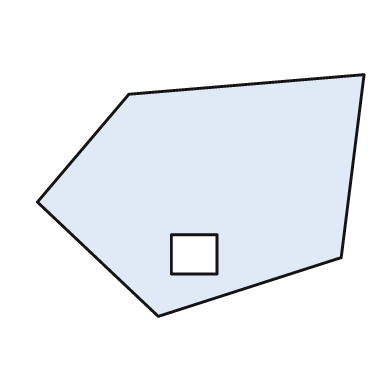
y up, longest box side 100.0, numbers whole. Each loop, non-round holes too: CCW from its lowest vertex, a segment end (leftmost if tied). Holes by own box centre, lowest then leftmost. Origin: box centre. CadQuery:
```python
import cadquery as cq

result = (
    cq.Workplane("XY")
    .moveTo(-13.0, -37.0)
    .lineTo(43.0, -19.0)
    .lineTo(50.0, 37.0)
    .lineTo(-22.0, 31.0)
    .lineTo(-50.0, -2.0)
    .close()
    .moveTo(-9.0, -24.0)
    .lineTo(5.0, -24.0)
    .lineTo(5.0, -12.0)
    .lineTo(-9.0, -12.0)
    .close()
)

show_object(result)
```